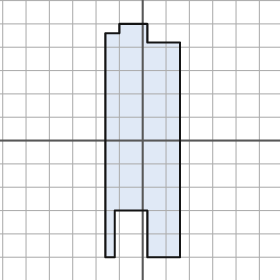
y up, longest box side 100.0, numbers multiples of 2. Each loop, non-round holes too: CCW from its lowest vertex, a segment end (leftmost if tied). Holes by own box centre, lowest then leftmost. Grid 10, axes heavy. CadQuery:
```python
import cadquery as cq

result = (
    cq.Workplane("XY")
    .moveTo(-16.0, -50.0)
    .lineTo(-12.0, -50.0)
    .lineTo(-12.0, -30.0)
    .lineTo(2.0, -30.0)
    .lineTo(2.0, -50.0)
    .lineTo(16.0, -50.0)
    .lineTo(16.0, 42.0)
    .lineTo(2.0, 42.0)
    .lineTo(2.0, 50.0)
    .lineTo(-10.0, 50.0)
    .lineTo(-10.0, 46.0)
    .lineTo(-16.0, 46.0)
    .close()
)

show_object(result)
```